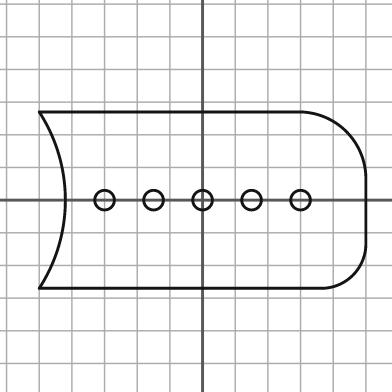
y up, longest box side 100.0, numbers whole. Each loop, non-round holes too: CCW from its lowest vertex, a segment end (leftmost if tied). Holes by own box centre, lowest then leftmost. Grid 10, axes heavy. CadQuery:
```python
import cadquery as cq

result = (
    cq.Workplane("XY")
    .moveTo(-50.0, -27.0)
    .lineTo(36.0, -27.0)
    .threePointArc((46.0, -23.0), (50.0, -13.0))
    .lineTo(50.0, 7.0)
    .threePointArc((44.0, 21.0), (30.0, 27.0))
    .lineTo(-50.0, 27.0)
    .threePointArc((-42.0, 0.0), (-50.0, -27.0))
    .close()
    .moveTo(-30.0, 0.0)
    .circle(3.0)
    .moveTo(-15.0, 0.0)
    .circle(3.0)
    .moveTo(0.0, 0.0)
    .circle(3.0)
    .moveTo(15.0, 0.0)
    .circle(3.0)
    .moveTo(30.0, 0.0)
    .circle(3.0)
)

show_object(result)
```